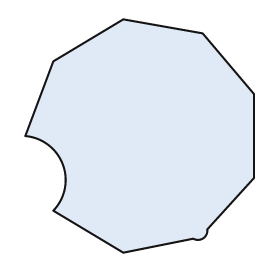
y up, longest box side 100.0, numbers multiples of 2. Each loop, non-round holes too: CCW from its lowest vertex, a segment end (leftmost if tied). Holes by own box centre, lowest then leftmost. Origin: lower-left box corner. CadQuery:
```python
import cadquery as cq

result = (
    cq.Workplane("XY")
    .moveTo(42.0, 0.0)
    .lineTo(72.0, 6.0)
    .threePointArc((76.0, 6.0), (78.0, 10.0))
    .lineTo(98.0, 32.0)
    .lineTo(98.0, 68.0)
    .lineTo(76.0, 94.0)
    .lineTo(42.0, 100.0)
    .lineTo(12.0, 82.0)
    .lineTo(0.0, 50.0)
    .threePointArc((16.0, 38.0), (12.0, 18.0))
    .close()
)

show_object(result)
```